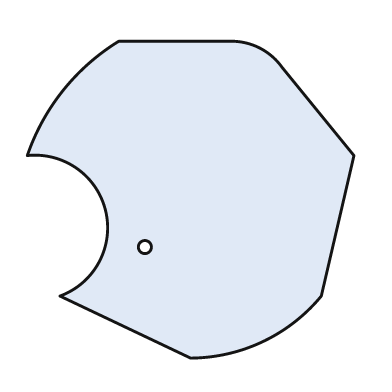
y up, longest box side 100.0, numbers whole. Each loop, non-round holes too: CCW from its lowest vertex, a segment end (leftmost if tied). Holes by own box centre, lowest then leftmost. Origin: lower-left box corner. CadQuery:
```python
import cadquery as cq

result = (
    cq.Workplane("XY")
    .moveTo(50.0, 0.0)
    .threePointArc((72.0, 5.0), (90.0, 19.0))
    .lineTo(100.0, 62.0)
    .lineTo(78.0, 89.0)
    .threePointArc((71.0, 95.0), (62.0, 97.0))
    .lineTo(28.0, 97.0)
    .threePointArc((11.0, 82.0), (0.0, 62.0))
    .threePointArc((24.0, 45.0), (10.0, 19.0))
    .close()
    .moveTo(36.0, 34.0)
    .circle(2.0)
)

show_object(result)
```